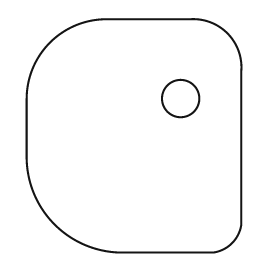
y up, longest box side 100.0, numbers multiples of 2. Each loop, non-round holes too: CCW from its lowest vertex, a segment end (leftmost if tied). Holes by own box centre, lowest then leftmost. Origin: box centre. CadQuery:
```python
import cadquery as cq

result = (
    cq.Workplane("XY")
    .moveTo(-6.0, -50.0)
    .lineTo(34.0, -50.0)
    .threePointArc((42.0, -46.0), (46.0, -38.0))
    .lineTo(46.0, 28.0)
    .threePointArc((40.0, 44.0), (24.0, 50.0))
    .lineTo(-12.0, 50.0)
    .threePointArc((-36.0, 40.0), (-46.0, 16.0))
    .lineTo(-46.0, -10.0)
    .threePointArc((-34.0, -38.0), (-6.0, -50.0))
    .close()
    .moveTo(20.0, 16.0)
    .circle(8.0)
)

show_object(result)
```